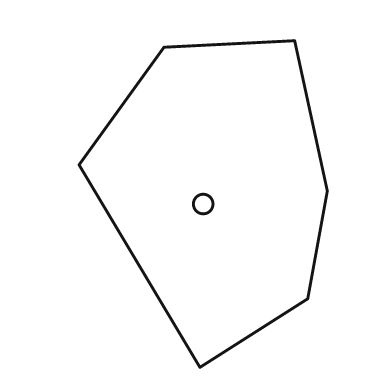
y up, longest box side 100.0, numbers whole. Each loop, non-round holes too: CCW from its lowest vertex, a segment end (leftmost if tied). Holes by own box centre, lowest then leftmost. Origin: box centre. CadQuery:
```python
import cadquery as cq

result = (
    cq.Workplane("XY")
    .moveTo(-1.0, -50.0)
    .lineTo(32.0, -29.0)
    .lineTo(38.0, 4.0)
    .lineTo(28.0, 50.0)
    .lineTo(-12.0, 48.0)
    .lineTo(-38.0, 12.0)
    .close()
    .moveTo(0.0, 0.0)
    .circle(3.0)
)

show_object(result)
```